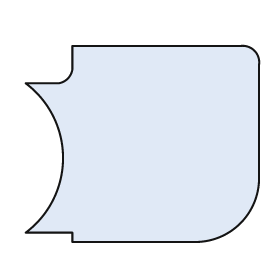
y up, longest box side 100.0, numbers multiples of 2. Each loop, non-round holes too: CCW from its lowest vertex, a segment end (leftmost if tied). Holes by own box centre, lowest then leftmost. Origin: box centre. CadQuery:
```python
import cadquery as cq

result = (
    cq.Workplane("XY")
    .moveTo(-30.0, -42.0)
    .lineTo(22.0, -42.0)
    .threePointArc((42.0, -34.0), (50.0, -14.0))
    .lineTo(50.0, 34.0)
    .threePointArc((48.0, 40.0), (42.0, 42.0))
    .lineTo(-30.0, 42.0)
    .lineTo(-30.0, 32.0)
    .threePointArc((-32.0, 28.0), (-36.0, 26.0))
    .lineTo(-50.0, 26.0)
    .threePointArc((-34.0, -6.0), (-50.0, -38.0))
    .lineTo(-30.0, -38.0)
    .close()
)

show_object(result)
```